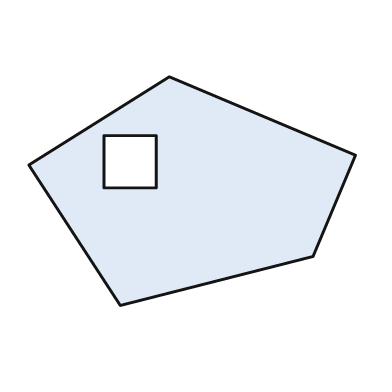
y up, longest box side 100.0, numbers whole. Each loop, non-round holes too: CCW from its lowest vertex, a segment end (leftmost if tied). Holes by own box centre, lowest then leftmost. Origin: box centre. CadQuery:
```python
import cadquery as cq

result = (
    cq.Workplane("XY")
    .moveTo(-22.0, -35.0)
    .lineTo(37.0, -20.0)
    .lineTo(50.0, 11.0)
    .lineTo(-7.0, 35.0)
    .lineTo(-50.0, 8.0)
    .close()
    .moveTo(-27.0, 1.0)
    .lineTo(-11.0, 1.0)
    .lineTo(-11.0, 17.0)
    .lineTo(-27.0, 17.0)
    .close()
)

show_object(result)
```